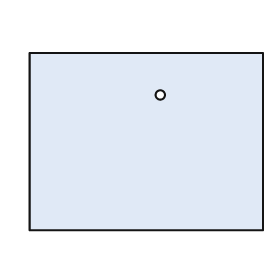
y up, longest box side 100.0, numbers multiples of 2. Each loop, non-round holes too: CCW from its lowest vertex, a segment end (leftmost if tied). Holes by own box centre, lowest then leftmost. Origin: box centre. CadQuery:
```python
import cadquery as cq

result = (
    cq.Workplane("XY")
    .moveTo(-50.0, -38.0)
    .lineTo(50.0, -38.0)
    .lineTo(50.0, 38.0)
    .lineTo(-50.0, 38.0)
    .close()
    .moveTo(6.0, 20.0)
    .circle(2.0)
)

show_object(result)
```